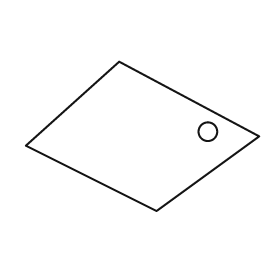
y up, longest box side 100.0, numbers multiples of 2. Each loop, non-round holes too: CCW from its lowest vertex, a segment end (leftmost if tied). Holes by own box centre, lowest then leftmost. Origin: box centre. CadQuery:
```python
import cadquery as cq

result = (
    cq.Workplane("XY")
    .moveTo(6.0, -32.0)
    .lineTo(50.0, 0.0)
    .lineTo(-10.0, 32.0)
    .lineTo(-50.0, -4.0)
    .close()
    .moveTo(28.0, 2.0)
    .circle(4.0)
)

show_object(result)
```